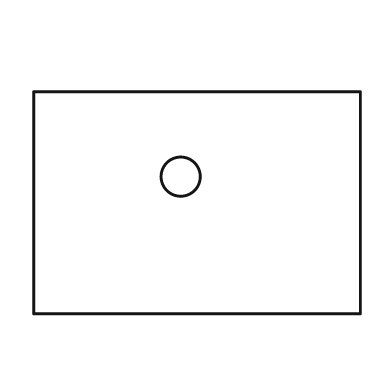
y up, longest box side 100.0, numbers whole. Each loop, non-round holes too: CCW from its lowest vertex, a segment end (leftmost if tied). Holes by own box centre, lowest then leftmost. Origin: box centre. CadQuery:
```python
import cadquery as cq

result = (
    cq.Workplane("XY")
    .moveTo(-50.0, -34.0)
    .lineTo(50.0, -34.0)
    .lineTo(50.0, 34.0)
    .lineTo(-50.0, 34.0)
    .close()
    .moveTo(-5.0, 8.0)
    .circle(6.0)
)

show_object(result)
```